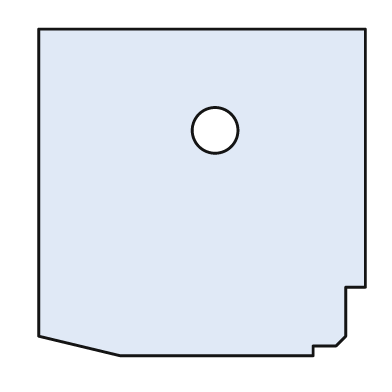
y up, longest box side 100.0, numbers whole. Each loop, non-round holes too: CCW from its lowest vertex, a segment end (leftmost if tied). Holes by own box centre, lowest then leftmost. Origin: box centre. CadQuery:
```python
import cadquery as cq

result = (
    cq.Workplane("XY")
    .moveTo(-25.0, -50.0)
    .lineTo(34.0, -50.0)
    .lineTo(34.0, -47.0)
    .lineTo(41.0, -47.0)
    .lineTo(44.0, -44.0)
    .lineTo(44.0, -29.0)
    .lineTo(50.0, -29.0)
    .lineTo(50.0, 50.0)
    .lineTo(-50.0, 50.0)
    .lineTo(-50.0, -44.0)
    .close()
    .moveTo(4.0, 19.0)
    .circle(7.0)
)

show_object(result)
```